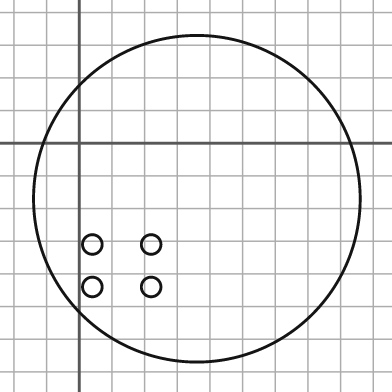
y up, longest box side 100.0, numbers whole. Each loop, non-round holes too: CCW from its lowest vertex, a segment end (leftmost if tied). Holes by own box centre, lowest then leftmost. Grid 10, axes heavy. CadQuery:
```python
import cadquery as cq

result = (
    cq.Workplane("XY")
    .moveTo(36.0, -17.0)
    .circle(50.0)
    .moveTo(4.0, -44.0)
    .circle(3.0)
    .moveTo(22.0, -44.0)
    .circle(3.0)
    .moveTo(4.0, -31.0)
    .circle(3.0)
    .moveTo(22.0, -31.0)
    .circle(3.0)
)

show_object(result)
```